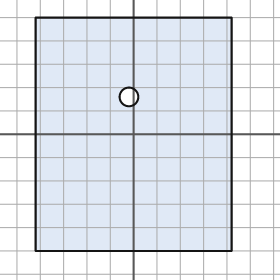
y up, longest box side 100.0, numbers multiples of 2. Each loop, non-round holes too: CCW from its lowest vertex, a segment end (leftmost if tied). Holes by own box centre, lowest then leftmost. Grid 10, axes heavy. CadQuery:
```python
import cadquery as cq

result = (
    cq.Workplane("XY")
    .moveTo(-42.0, -50.0)
    .lineTo(42.0, -50.0)
    .lineTo(42.0, 50.0)
    .lineTo(-42.0, 50.0)
    .close()
    .moveTo(-2.0, 16.0)
    .circle(4.0)
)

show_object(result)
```